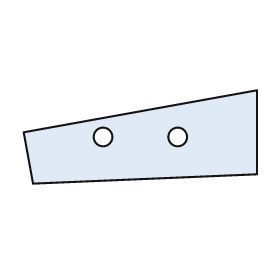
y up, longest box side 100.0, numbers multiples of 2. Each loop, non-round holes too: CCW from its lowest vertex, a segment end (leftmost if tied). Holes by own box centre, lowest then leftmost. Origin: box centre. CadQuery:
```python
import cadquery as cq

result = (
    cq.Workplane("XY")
    .moveTo(-46.0, -20.0)
    .lineTo(50.0, -16.0)
    .lineTo(50.0, 20.0)
    .lineTo(-50.0, 2.0)
    .close()
    .moveTo(-16.0, 0.0)
    .circle(4.0)
    .moveTo(16.0, 0.0)
    .circle(4.0)
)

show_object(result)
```